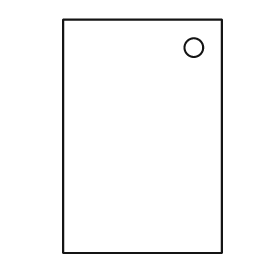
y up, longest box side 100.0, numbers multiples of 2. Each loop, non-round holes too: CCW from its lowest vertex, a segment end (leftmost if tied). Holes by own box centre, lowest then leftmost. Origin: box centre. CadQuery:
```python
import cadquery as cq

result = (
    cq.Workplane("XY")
    .moveTo(-34.0, -50.0)
    .lineTo(34.0, -50.0)
    .lineTo(34.0, 50.0)
    .lineTo(-34.0, 50.0)
    .close()
    .moveTo(22.0, 38.0)
    .circle(4.0)
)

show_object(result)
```